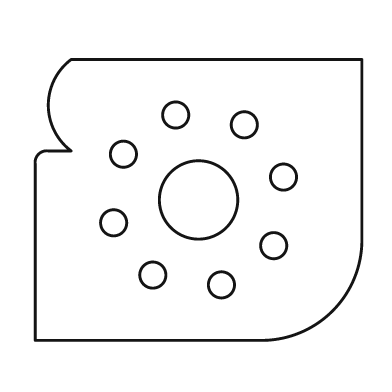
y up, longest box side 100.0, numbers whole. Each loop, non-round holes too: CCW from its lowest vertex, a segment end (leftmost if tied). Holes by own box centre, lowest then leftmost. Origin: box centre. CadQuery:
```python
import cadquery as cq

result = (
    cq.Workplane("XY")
    .moveTo(-50.0, -43.0)
    .lineTo(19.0, -43.0)
    .threePointArc((41.0, -34.0), (50.0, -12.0))
    .lineTo(50.0, 43.0)
    .lineTo(-39.0, 43.0)
    .threePointArc((-46.0, 29.0), (-39.0, 15.0))
    .lineTo(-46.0, 15.0)
    .threePointArc((-49.0, 14.0), (-50.0, 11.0))
    .close()
    .moveTo(7.0, -26.0)
    .circle(4.0)
    .moveTo(-14.0, -23.0)
    .circle(4.0)
    .moveTo(23.0, -14.0)
    .circle(4.0)
    .moveTo(-26.0, -7.0)
    .circle(4.0)
    .moveTo(0.0, 0.0)
    .circle(12.0)
    .moveTo(26.0, 7.0)
    .circle(4.0)
    .moveTo(-23.0, 14.0)
    .circle(4.0)
    .moveTo(14.0, 23.0)
    .circle(4.0)
    .moveTo(-7.0, 26.0)
    .circle(4.0)
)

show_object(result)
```